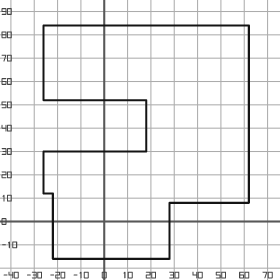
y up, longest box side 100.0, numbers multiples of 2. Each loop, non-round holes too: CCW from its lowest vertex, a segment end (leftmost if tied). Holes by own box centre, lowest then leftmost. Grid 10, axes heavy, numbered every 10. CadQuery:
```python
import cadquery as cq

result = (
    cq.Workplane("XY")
    .moveTo(-22.0, -16.0)
    .lineTo(28.0, -16.0)
    .lineTo(28.0, 8.0)
    .lineTo(62.0, 8.0)
    .lineTo(62.0, 84.0)
    .lineTo(-26.0, 84.0)
    .lineTo(-26.0, 52.0)
    .lineTo(18.0, 52.0)
    .lineTo(18.0, 30.0)
    .lineTo(-26.0, 30.0)
    .lineTo(-26.0, 12.0)
    .lineTo(-22.0, 12.0)
    .close()
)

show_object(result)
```